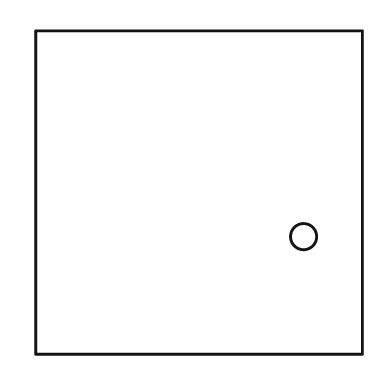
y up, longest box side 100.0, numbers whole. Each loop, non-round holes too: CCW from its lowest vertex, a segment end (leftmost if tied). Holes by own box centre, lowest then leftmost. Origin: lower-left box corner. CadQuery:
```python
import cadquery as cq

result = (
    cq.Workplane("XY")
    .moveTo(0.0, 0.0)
    .lineTo(100.0, 0.0)
    .lineTo(100.0, 99.0)
    .lineTo(0.0, 99.0)
    .close()
    .moveTo(82.0, 36.0)
    .circle(4.0)
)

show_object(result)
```